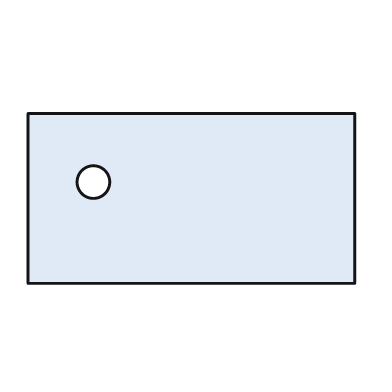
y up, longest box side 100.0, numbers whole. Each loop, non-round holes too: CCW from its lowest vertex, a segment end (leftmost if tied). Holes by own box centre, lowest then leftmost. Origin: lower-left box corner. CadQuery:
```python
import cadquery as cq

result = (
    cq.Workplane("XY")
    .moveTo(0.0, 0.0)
    .lineTo(100.0, 0.0)
    .lineTo(100.0, 52.0)
    .lineTo(0.0, 52.0)
    .close()
    .moveTo(20.0, 31.0)
    .circle(5.0)
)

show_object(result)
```